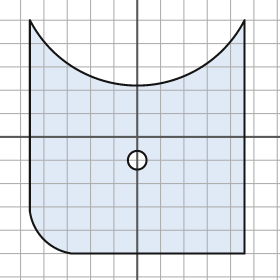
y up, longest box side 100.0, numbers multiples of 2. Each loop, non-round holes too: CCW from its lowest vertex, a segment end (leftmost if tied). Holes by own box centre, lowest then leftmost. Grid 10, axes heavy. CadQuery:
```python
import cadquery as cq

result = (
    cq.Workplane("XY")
    .moveTo(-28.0, -50.0)
    .lineTo(46.0, -50.0)
    .lineTo(46.0, 50.0)
    .threePointArc((0.0, 22.0), (-46.0, 50.0))
    .lineTo(-46.0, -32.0)
    .threePointArc((-40.0, -44.0), (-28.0, -50.0))
    .close()
    .moveTo(0.0, -10.0)
    .circle(4.0)
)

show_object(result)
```